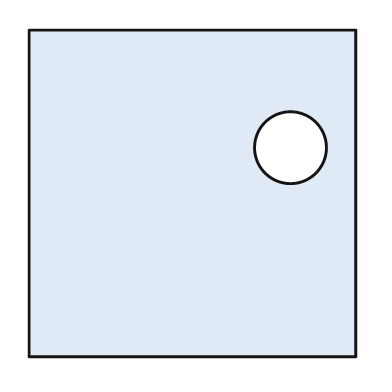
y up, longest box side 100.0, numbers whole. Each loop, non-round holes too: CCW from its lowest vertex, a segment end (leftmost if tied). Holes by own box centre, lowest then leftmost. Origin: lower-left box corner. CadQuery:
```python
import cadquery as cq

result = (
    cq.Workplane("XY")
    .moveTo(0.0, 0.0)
    .lineTo(100.0, 0.0)
    .lineTo(100.0, 100.0)
    .lineTo(0.0, 100.0)
    .close()
    .moveTo(80.0, 64.0)
    .circle(11.0)
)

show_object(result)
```